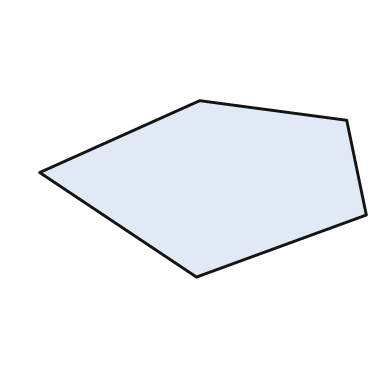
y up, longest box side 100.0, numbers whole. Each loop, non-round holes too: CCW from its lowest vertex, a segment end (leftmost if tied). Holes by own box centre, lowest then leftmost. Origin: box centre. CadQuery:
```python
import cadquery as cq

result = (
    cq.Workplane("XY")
    .moveTo(-2.0, -27.0)
    .lineTo(50.0, -8.0)
    .lineTo(44.0, 21.0)
    .lineTo(-1.0, 27.0)
    .lineTo(-50.0, 5.0)
    .close()
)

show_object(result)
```